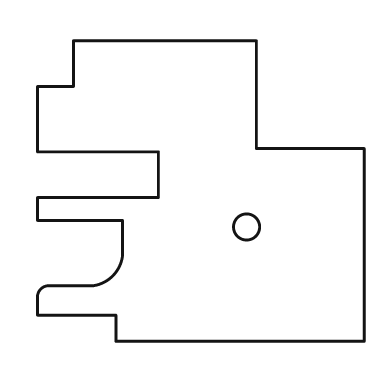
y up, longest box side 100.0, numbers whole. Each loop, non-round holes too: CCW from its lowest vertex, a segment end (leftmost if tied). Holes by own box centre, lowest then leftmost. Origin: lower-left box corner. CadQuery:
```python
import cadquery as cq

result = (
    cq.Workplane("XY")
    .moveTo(24.0, 0.0)
    .lineTo(100.0, 0.0)
    .lineTo(100.0, 59.0)
    .lineTo(67.0, 59.0)
    .lineTo(67.0, 92.0)
    .lineTo(11.0, 92.0)
    .lineTo(11.0, 78.0)
    .lineTo(0.0, 78.0)
    .lineTo(0.0, 58.0)
    .lineTo(37.0, 58.0)
    .lineTo(37.0, 44.0)
    .lineTo(0.0, 44.0)
    .lineTo(0.0, 37.0)
    .lineTo(26.0, 37.0)
    .lineTo(26.0, 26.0)
    .threePointArc((23.0, 20.0), (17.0, 17.0))
    .lineTo(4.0, 17.0)
    .threePointArc((1.0, 16.0), (0.0, 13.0))
    .lineTo(0.0, 8.0)
    .lineTo(24.0, 8.0)
    .close()
    .moveTo(64.0, 35.0)
    .circle(4.0)
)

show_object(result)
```